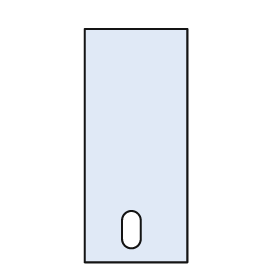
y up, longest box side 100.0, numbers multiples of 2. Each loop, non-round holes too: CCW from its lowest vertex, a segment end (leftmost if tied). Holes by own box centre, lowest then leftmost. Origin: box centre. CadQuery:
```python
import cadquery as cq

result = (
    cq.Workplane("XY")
    .moveTo(-22.0, -50.0)
    .lineTo(22.0, -50.0)
    .lineTo(22.0, 50.0)
    .lineTo(-22.0, 50.0)
    .close()
    .moveTo(-6.0, -40.0)
    .threePointArc((-2.0, -44.0), (2.0, -40.0))
    .lineTo(2.0, -32.0)
    .threePointArc((-2.0, -28.0), (-6.0, -32.0))
    .close()
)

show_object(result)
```